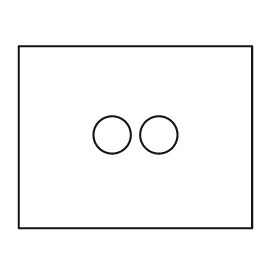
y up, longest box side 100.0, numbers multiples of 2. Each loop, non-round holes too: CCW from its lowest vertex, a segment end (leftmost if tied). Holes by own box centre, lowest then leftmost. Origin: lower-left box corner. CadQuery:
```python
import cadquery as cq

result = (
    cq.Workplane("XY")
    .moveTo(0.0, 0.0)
    .lineTo(100.0, 0.0)
    .lineTo(100.0, 78.0)
    .lineTo(0.0, 78.0)
    .close()
    .moveTo(40.0, 40.0)
    .circle(8.0)
    .moveTo(60.0, 40.0)
    .circle(8.0)
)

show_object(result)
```